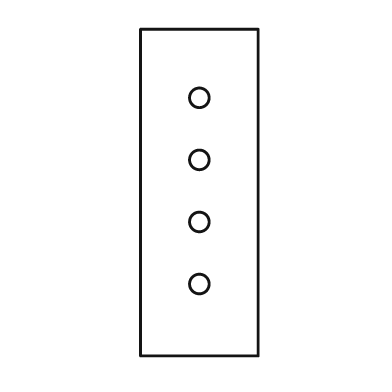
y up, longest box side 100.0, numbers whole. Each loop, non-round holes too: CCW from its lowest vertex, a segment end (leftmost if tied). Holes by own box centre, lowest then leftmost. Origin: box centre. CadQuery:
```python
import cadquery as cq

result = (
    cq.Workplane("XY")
    .moveTo(-18.0, -50.0)
    .lineTo(18.0, -50.0)
    .lineTo(18.0, 50.0)
    .lineTo(-18.0, 50.0)
    .close()
    .moveTo(0.0, -28.0)
    .circle(3.0)
    .moveTo(0.0, -9.0)
    .circle(3.0)
    .moveTo(0.0, 10.0)
    .circle(3.0)
    .moveTo(0.0, 29.0)
    .circle(3.0)
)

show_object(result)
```